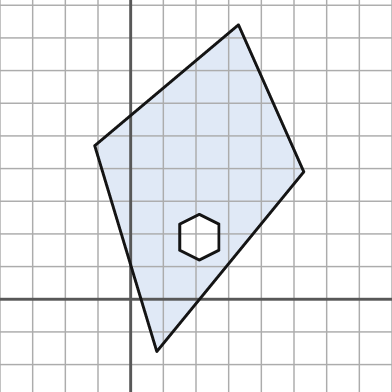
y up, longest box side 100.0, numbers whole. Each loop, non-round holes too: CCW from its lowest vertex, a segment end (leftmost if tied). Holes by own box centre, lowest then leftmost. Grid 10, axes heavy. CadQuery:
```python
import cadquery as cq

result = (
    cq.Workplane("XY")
    .moveTo(8.0, -16.0)
    .lineTo(53.0, 39.0)
    .lineTo(33.0, 84.0)
    .lineTo(-11.0, 47.0)
    .close()
    .moveTo(21.0, 12.0)
    .lineTo(27.0, 15.0)
    .lineTo(27.0, 23.0)
    .lineTo(21.0, 26.0)
    .lineTo(15.0, 23.0)
    .lineTo(15.0, 15.0)
    .close()
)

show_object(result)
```